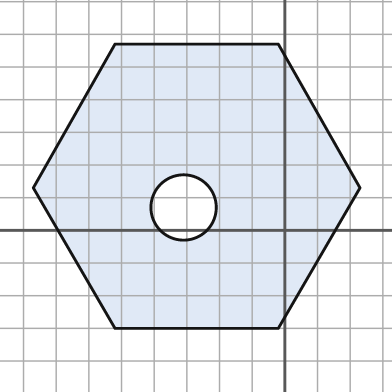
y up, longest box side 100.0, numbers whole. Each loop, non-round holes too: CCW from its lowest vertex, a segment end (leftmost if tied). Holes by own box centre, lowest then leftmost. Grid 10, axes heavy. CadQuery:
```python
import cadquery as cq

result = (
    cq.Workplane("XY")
    .moveTo(-52.0, -30.0)
    .lineTo(-2.0, -30.0)
    .lineTo(23.0, 13.0)
    .lineTo(-2.0, 57.0)
    .lineTo(-52.0, 57.0)
    .lineTo(-77.0, 13.0)
    .close()
    .moveTo(-31.0, 7.0)
    .circle(10.0)
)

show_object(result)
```